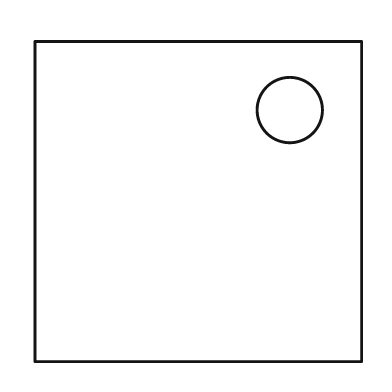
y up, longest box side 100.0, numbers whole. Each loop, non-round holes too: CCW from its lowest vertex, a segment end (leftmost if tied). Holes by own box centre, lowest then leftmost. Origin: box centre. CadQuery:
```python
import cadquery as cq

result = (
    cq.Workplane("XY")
    .moveTo(-50.0, -49.0)
    .lineTo(50.0, -49.0)
    .lineTo(50.0, 49.0)
    .lineTo(-50.0, 49.0)
    .close()
    .moveTo(28.0, 28.0)
    .circle(10.0)
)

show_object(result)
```